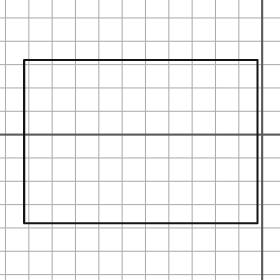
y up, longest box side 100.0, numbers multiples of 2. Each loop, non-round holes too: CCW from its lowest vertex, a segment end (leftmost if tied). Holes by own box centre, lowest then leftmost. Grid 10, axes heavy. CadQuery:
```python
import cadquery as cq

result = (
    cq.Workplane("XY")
    .moveTo(-102.0, -38.0)
    .lineTo(-2.0, -38.0)
    .lineTo(-2.0, 32.0)
    .lineTo(-102.0, 32.0)
    .close()
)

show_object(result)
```